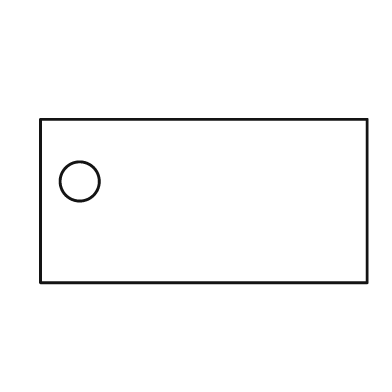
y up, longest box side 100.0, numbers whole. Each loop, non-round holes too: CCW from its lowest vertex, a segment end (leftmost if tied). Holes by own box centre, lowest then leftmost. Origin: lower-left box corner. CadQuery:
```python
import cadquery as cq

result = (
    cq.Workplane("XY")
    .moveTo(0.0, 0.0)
    .lineTo(100.0, 0.0)
    .lineTo(100.0, 50.0)
    .lineTo(0.0, 50.0)
    .close()
    .moveTo(12.0, 31.0)
    .circle(6.0)
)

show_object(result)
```